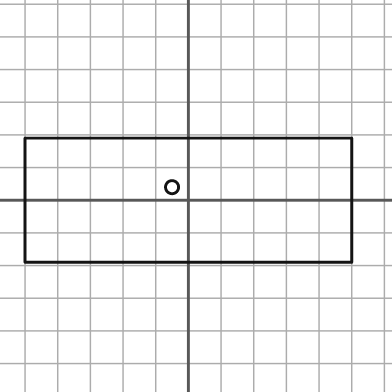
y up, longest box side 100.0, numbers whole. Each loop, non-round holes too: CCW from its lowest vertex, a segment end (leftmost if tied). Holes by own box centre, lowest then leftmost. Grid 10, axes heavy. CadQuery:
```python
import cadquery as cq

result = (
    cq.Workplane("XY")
    .moveTo(-50.0, -19.0)
    .lineTo(50.0, -19.0)
    .lineTo(50.0, 19.0)
    .lineTo(-50.0, 19.0)
    .close()
    .moveTo(-5.0, 4.0)
    .circle(2.0)
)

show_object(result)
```